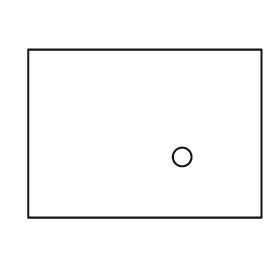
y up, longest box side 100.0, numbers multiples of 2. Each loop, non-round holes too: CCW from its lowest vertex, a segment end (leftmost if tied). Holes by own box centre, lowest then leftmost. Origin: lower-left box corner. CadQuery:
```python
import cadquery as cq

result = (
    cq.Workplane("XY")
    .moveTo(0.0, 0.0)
    .lineTo(100.0, 0.0)
    .lineTo(100.0, 72.0)
    .lineTo(0.0, 72.0)
    .close()
    .moveTo(66.0, 26.0)
    .circle(4.0)
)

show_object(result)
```